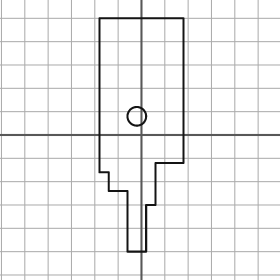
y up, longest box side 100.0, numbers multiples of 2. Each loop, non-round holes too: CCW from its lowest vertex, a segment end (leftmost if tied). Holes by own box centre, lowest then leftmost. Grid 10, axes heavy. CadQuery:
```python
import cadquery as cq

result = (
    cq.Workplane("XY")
    .moveTo(-6.0, -50.0)
    .lineTo(2.0, -50.0)
    .lineTo(2.0, -30.0)
    .lineTo(6.0, -30.0)
    .lineTo(6.0, -12.0)
    .lineTo(18.0, -12.0)
    .lineTo(18.0, 50.0)
    .lineTo(-18.0, 50.0)
    .lineTo(-18.0, -16.0)
    .lineTo(-14.0, -16.0)
    .lineTo(-14.0, -24.0)
    .lineTo(-6.0, -24.0)
    .close()
    .moveTo(-2.0, 8.0)
    .circle(4.0)
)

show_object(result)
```